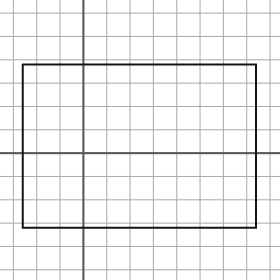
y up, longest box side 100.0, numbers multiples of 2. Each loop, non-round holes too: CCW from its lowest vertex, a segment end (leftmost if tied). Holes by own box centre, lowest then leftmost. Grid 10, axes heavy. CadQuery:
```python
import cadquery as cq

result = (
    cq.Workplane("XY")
    .moveTo(-26.0, -32.0)
    .lineTo(74.0, -32.0)
    .lineTo(74.0, 38.0)
    .lineTo(-26.0, 38.0)
    .close()
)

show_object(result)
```